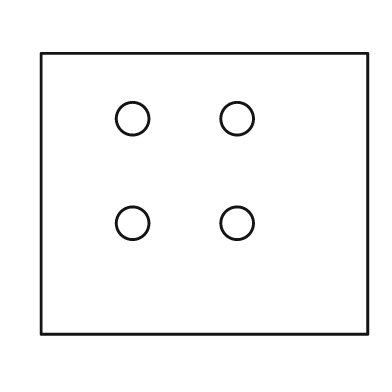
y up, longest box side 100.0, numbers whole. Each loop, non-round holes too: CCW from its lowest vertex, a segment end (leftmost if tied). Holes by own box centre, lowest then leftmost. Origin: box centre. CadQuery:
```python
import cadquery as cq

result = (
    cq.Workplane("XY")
    .moveTo(-50.0, -43.0)
    .lineTo(50.0, -43.0)
    .lineTo(50.0, 43.0)
    .lineTo(-50.0, 43.0)
    .close()
    .moveTo(-22.0, -9.0)
    .circle(5.0)
    .moveTo(10.0, -9.0)
    .circle(5.0)
    .moveTo(-22.0, 23.0)
    .circle(5.0)
    .moveTo(10.0, 23.0)
    .circle(5.0)
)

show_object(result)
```